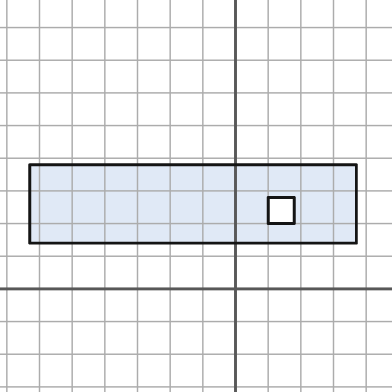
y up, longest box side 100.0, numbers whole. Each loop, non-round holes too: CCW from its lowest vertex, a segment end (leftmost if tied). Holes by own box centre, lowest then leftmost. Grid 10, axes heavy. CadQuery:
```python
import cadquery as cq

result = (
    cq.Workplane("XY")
    .moveTo(-63.0, 14.0)
    .lineTo(37.0, 14.0)
    .lineTo(37.0, 38.0)
    .lineTo(-63.0, 38.0)
    .close()
    .moveTo(10.0, 20.0)
    .lineTo(18.0, 20.0)
    .lineTo(18.0, 28.0)
    .lineTo(10.0, 28.0)
    .close()
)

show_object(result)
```